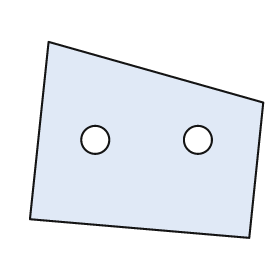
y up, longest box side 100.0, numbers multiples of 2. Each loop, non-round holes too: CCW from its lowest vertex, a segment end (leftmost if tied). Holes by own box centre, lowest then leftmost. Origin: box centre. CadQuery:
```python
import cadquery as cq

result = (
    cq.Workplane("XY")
    .moveTo(44.0, -42.0)
    .lineTo(50.0, 16.0)
    .lineTo(-42.0, 42.0)
    .lineTo(-50.0, -34.0)
    .close()
    .moveTo(-22.0, 0.0)
    .circle(6.0)
    .moveTo(22.0, 0.0)
    .circle(6.0)
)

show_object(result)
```